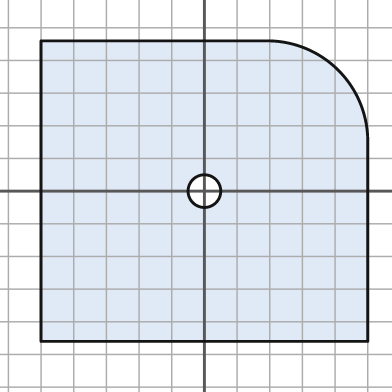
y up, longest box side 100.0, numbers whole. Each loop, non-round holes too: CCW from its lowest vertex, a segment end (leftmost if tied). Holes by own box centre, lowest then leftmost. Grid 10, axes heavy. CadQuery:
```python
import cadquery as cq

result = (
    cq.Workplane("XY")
    .moveTo(-50.0, -46.0)
    .lineTo(50.0, -46.0)
    .lineTo(50.0, 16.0)
    .threePointArc((41.0, 37.0), (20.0, 46.0))
    .lineTo(-50.0, 46.0)
    .close()
    .moveTo(0.0, 0.0)
    .circle(5.0)
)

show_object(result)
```